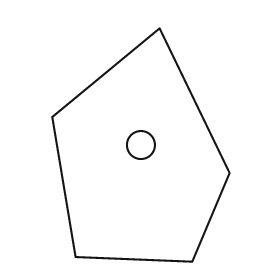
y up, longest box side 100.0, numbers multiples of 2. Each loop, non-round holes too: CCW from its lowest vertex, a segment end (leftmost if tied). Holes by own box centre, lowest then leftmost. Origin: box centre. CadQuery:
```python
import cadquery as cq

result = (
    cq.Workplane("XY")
    .moveTo(22.0, -50.0)
    .lineTo(38.0, -12.0)
    .lineTo(8.0, 50.0)
    .lineTo(-38.0, 12.0)
    .lineTo(-28.0, -48.0)
    .close()
    .moveTo(0.0, 0.0)
    .circle(6.0)
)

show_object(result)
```